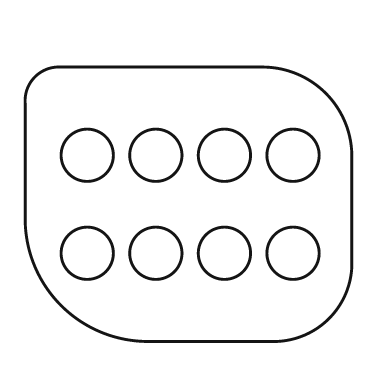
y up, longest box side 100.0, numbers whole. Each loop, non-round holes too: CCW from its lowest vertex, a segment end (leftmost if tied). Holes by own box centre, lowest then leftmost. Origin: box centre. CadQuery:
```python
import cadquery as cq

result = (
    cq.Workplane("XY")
    .moveTo(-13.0, -42.0)
    .lineTo(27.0, -42.0)
    .threePointArc((43.0, -35.0), (50.0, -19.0))
    .lineTo(50.0, 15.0)
    .threePointArc((42.0, 34.0), (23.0, 42.0))
    .lineTo(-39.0, 42.0)
    .threePointArc((-47.0, 39.0), (-50.0, 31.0))
    .lineTo(-50.0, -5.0)
    .threePointArc((-39.0, -31.0), (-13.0, -42.0))
    .close()
    .moveTo(-31.0, -15.0)
    .circle(8.0)
    .moveTo(-10.0, -15.0)
    .circle(8.0)
    .moveTo(11.0, -15.0)
    .circle(8.0)
    .moveTo(32.0, -15.0)
    .circle(8.0)
    .moveTo(-31.0, 15.0)
    .circle(8.0)
    .moveTo(-10.0, 15.0)
    .circle(8.0)
    .moveTo(11.0, 15.0)
    .circle(8.0)
    .moveTo(32.0, 15.0)
    .circle(8.0)
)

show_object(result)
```